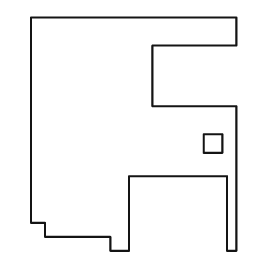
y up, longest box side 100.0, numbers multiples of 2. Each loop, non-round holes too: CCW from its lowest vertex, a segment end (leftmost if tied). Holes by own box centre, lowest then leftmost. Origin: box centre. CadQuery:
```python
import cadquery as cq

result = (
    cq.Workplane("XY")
    .moveTo(-10.0, -50.0)
    .lineTo(-2.0, -50.0)
    .lineTo(-2.0, -18.0)
    .lineTo(40.0, -18.0)
    .lineTo(40.0, -50.0)
    .lineTo(44.0, -50.0)
    .lineTo(44.0, 12.0)
    .lineTo(8.0, 12.0)
    .lineTo(8.0, 38.0)
    .lineTo(44.0, 38.0)
    .lineTo(44.0, 50.0)
    .lineTo(-44.0, 50.0)
    .lineTo(-44.0, -38.0)
    .lineTo(-38.0, -38.0)
    .lineTo(-38.0, -44.0)
    .lineTo(-10.0, -44.0)
    .close()
    .moveTo(30.0, -8.0)
    .lineTo(38.0, -8.0)
    .lineTo(38.0, 0.0)
    .lineTo(30.0, 0.0)
    .close()
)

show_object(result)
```